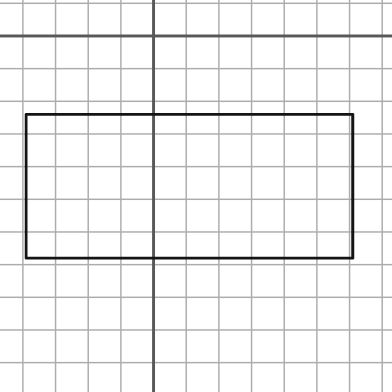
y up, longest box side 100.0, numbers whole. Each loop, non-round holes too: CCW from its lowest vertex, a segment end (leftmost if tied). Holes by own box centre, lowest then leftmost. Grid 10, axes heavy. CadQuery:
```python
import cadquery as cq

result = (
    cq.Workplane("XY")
    .moveTo(-39.0, -68.0)
    .lineTo(61.0, -68.0)
    .lineTo(61.0, -24.0)
    .lineTo(-39.0, -24.0)
    .close()
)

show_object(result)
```